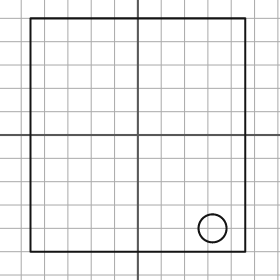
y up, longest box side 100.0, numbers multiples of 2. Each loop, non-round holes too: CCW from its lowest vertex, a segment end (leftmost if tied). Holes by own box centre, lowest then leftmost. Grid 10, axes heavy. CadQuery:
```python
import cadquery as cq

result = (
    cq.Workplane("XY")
    .moveTo(-46.0, -50.0)
    .lineTo(46.0, -50.0)
    .lineTo(46.0, 50.0)
    .lineTo(-46.0, 50.0)
    .close()
    .moveTo(32.0, -40.0)
    .circle(6.0)
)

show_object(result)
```